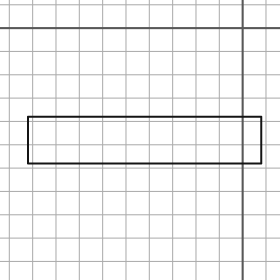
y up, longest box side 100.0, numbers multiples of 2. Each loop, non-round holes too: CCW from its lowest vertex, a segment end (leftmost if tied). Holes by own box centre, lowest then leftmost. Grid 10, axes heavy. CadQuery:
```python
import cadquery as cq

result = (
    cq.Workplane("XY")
    .moveTo(-92.0, -58.0)
    .lineTo(8.0, -58.0)
    .lineTo(8.0, -38.0)
    .lineTo(-92.0, -38.0)
    .close()
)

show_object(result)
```